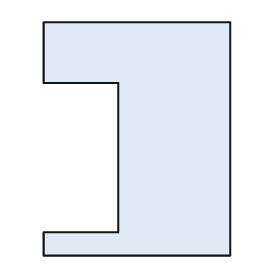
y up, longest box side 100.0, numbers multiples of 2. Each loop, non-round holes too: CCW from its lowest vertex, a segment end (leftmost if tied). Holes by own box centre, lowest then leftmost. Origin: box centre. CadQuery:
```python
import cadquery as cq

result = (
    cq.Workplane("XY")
    .moveTo(-40.0, -50.0)
    .lineTo(40.0, -50.0)
    .lineTo(40.0, 50.0)
    .lineTo(-40.0, 50.0)
    .lineTo(-40.0, 24.0)
    .lineTo(-8.0, 24.0)
    .lineTo(-8.0, -40.0)
    .lineTo(-40.0, -40.0)
    .close()
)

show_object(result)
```